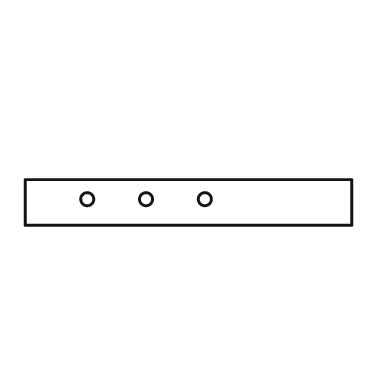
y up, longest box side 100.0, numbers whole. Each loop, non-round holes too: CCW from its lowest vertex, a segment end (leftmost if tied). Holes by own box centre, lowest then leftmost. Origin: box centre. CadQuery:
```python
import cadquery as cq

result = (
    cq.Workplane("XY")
    .moveTo(-50.0, -7.0)
    .lineTo(50.0, -7.0)
    .lineTo(50.0, 7.0)
    .lineTo(-50.0, 7.0)
    .close()
    .moveTo(-31.0, 1.0)
    .circle(2.0)
    .moveTo(-13.0, 1.0)
    .circle(2.0)
    .moveTo(5.0, 1.0)
    .circle(2.0)
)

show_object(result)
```